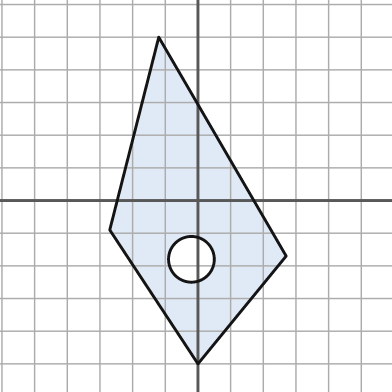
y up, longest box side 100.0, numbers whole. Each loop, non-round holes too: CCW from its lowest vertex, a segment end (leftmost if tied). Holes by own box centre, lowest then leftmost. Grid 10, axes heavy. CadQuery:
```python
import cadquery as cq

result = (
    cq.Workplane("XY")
    .moveTo(0.0, -50.0)
    .lineTo(27.0, -17.0)
    .lineTo(-12.0, 50.0)
    .lineTo(-27.0, -9.0)
    .close()
    .moveTo(-2.0, -18.0)
    .circle(7.0)
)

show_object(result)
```